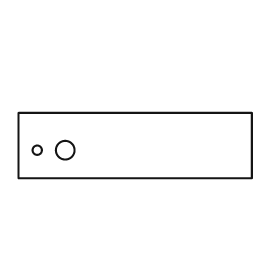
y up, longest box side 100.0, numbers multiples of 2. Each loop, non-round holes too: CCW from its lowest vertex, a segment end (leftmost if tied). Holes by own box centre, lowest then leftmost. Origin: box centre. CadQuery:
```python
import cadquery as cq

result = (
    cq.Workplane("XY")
    .moveTo(-50.0, -14.0)
    .lineTo(50.0, -14.0)
    .lineTo(50.0, 14.0)
    .lineTo(-50.0, 14.0)
    .close()
    .moveTo(-42.0, -2.0)
    .circle(2.0)
    .moveTo(-30.0, -2.0)
    .circle(4.0)
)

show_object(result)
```